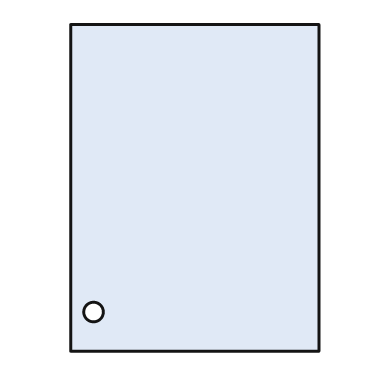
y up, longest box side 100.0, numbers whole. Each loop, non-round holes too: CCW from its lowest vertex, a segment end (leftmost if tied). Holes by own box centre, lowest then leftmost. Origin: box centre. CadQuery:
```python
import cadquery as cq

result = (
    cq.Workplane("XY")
    .moveTo(-38.0, -50.0)
    .lineTo(38.0, -50.0)
    .lineTo(38.0, 50.0)
    .lineTo(-38.0, 50.0)
    .close()
    .moveTo(-31.0, -38.0)
    .circle(3.0)
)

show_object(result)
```